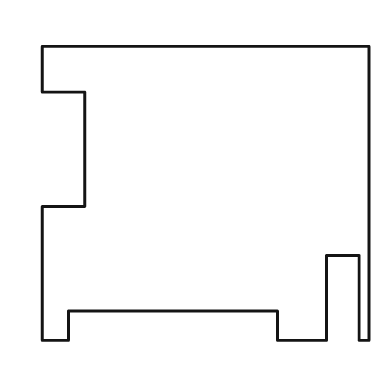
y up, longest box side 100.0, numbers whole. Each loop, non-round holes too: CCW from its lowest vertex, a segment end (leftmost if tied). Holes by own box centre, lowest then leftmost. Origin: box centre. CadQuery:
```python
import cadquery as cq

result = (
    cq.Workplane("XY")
    .moveTo(-50.0, -45.0)
    .lineTo(-42.0, -45.0)
    .lineTo(-42.0, -36.0)
    .lineTo(22.0, -36.0)
    .lineTo(22.0, -45.0)
    .lineTo(37.0, -45.0)
    .lineTo(37.0, -19.0)
    .lineTo(47.0, -19.0)
    .lineTo(47.0, -45.0)
    .lineTo(50.0, -45.0)
    .lineTo(50.0, 45.0)
    .lineTo(-50.0, 45.0)
    .lineTo(-50.0, 31.0)
    .lineTo(-37.0, 31.0)
    .lineTo(-37.0, -4.0)
    .lineTo(-50.0, -4.0)
    .close()
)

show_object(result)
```